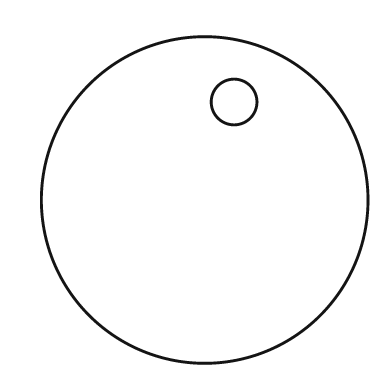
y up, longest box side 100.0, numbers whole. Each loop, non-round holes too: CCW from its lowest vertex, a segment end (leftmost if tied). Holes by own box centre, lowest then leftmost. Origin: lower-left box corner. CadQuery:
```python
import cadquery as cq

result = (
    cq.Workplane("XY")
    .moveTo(50.0, 50.0)
    .circle(50.0)
    .moveTo(59.0, 80.0)
    .circle(7.0)
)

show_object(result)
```